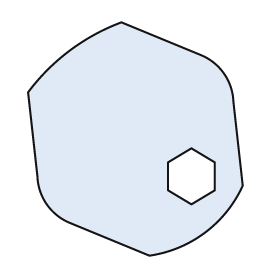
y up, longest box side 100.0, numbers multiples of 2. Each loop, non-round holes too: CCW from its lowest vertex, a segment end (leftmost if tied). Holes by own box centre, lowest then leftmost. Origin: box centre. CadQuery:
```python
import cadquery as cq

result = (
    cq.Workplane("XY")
    .moveTo(6.0, -50.0)
    .threePointArc((30.0, -40.0), (46.0, -20.0))
    .lineTo(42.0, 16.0)
    .threePointArc((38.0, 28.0), (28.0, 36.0))
    .lineTo(-6.0, 50.0)
    .threePointArc((-28.0, 38.0), (-46.0, 20.0))
    .lineTo(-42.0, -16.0)
    .threePointArc((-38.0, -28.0), (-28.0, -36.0))
    .close()
    .moveTo(24.0, -28.0)
    .lineTo(34.0, -22.0)
    .lineTo(34.0, -10.0)
    .lineTo(24.0, -4.0)
    .lineTo(14.0, -10.0)
    .lineTo(14.0, -22.0)
    .close()
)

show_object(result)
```